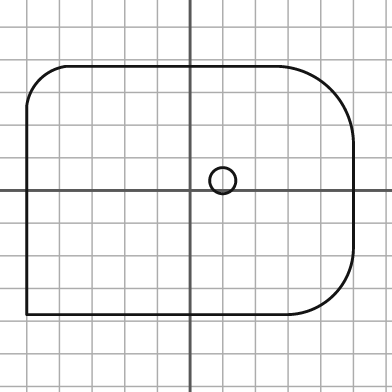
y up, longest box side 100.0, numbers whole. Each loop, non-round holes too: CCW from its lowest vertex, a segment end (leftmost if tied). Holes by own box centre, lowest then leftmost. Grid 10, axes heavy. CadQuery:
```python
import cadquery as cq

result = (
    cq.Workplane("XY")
    .moveTo(-50.0, -38.0)
    .lineTo(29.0, -38.0)
    .threePointArc((44.0, -32.0), (50.0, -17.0))
    .lineTo(50.0, 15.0)
    .threePointArc((43.0, 31.0), (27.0, 38.0))
    .lineTo(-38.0, 38.0)
    .threePointArc((-46.0, 34.0), (-50.0, 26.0))
    .close()
    .moveTo(10.0, 3.0)
    .circle(4.0)
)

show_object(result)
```